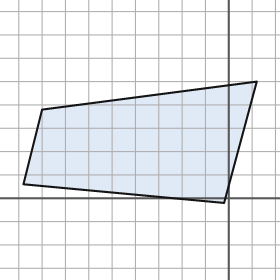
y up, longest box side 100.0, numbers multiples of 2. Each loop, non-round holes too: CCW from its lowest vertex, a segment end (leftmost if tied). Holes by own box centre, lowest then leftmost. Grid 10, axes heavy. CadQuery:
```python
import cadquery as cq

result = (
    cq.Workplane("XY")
    .moveTo(-2.0, -2.0)
    .lineTo(12.0, 50.0)
    .lineTo(-80.0, 38.0)
    .lineTo(-88.0, 6.0)
    .close()
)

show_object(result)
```